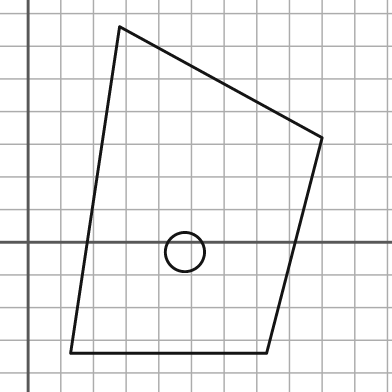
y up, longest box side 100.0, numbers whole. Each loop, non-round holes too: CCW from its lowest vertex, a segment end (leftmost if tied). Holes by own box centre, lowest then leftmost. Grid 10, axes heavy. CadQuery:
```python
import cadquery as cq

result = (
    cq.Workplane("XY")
    .moveTo(13.0, -34.0)
    .lineTo(73.0, -34.0)
    .lineTo(90.0, 32.0)
    .lineTo(28.0, 66.0)
    .close()
    .moveTo(48.0, -3.0)
    .circle(6.0)
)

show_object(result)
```